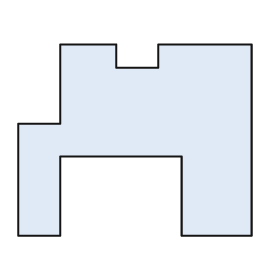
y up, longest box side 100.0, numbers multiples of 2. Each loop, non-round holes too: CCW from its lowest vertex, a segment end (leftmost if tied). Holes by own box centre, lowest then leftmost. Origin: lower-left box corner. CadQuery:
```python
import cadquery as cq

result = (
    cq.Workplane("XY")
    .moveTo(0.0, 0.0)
    .lineTo(18.0, 0.0)
    .lineTo(18.0, 34.0)
    .lineTo(70.0, 34.0)
    .lineTo(70.0, 0.0)
    .lineTo(100.0, 0.0)
    .lineTo(100.0, 82.0)
    .lineTo(60.0, 82.0)
    .lineTo(60.0, 72.0)
    .lineTo(42.0, 72.0)
    .lineTo(42.0, 82.0)
    .lineTo(18.0, 82.0)
    .lineTo(18.0, 48.0)
    .lineTo(0.0, 48.0)
    .close()
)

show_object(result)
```